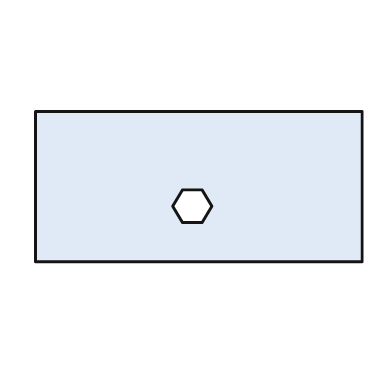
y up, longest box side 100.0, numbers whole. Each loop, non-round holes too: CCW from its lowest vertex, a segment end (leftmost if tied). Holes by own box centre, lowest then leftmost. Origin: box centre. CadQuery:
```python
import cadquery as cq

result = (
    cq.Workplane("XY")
    .moveTo(-50.0, -23.0)
    .lineTo(50.0, -23.0)
    .lineTo(50.0, 23.0)
    .lineTo(-50.0, 23.0)
    .close()
    .moveTo(-5.0, -11.0)
    .lineTo(1.0, -11.0)
    .lineTo(4.0, -6.0)
    .lineTo(1.0, -1.0)
    .lineTo(-5.0, -1.0)
    .lineTo(-8.0, -6.0)
    .close()
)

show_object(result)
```